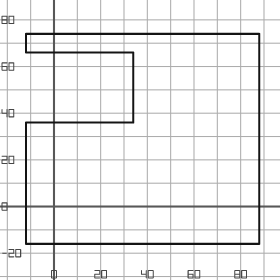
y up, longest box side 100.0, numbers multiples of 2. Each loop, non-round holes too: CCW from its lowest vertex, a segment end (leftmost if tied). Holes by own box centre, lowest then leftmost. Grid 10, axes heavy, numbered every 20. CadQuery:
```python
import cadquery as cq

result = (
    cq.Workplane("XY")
    .moveTo(-12.0, -16.0)
    .lineTo(88.0, -16.0)
    .lineTo(88.0, 74.0)
    .lineTo(-12.0, 74.0)
    .lineTo(-12.0, 66.0)
    .lineTo(34.0, 66.0)
    .lineTo(34.0, 36.0)
    .lineTo(-12.0, 36.0)
    .close()
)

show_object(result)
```